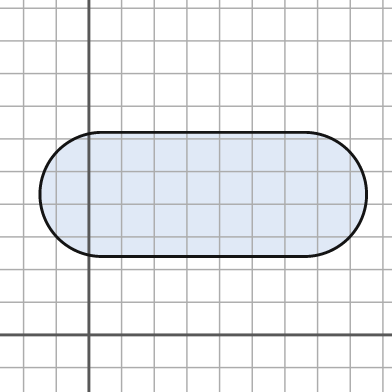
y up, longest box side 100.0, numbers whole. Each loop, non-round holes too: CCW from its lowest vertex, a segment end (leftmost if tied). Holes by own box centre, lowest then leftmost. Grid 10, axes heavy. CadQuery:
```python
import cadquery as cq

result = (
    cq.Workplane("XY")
    .moveTo(4.0, 24.0)
    .lineTo(66.0, 24.0)
    .threePointArc((85.0, 43.0), (66.0, 62.0))
    .lineTo(4.0, 62.0)
    .threePointArc((-15.0, 43.0), (4.0, 24.0))
    .close()
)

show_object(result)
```